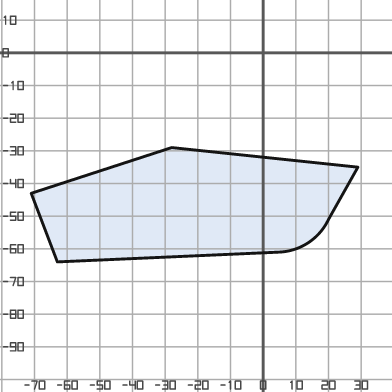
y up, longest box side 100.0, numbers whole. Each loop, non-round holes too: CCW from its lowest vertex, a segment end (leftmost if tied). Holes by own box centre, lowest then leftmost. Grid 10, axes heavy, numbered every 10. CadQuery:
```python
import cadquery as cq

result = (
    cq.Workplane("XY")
    .moveTo(-63.0, -64.0)
    .lineTo(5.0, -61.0)
    .threePointArc((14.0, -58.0), (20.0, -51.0))
    .lineTo(29.0, -35.0)
    .lineTo(-28.0, -29.0)
    .lineTo(-71.0, -43.0)
    .close()
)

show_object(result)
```